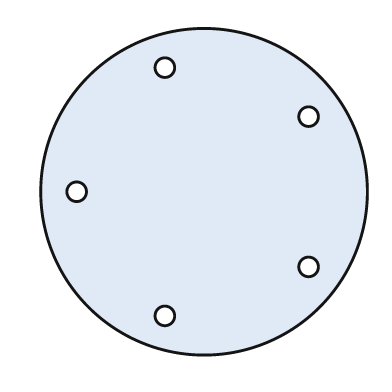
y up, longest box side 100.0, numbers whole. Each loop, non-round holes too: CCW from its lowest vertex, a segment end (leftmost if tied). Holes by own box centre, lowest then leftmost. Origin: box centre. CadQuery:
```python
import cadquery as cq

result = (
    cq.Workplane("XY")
    .moveTo(0.0, 0.0)
    .circle(50.0)
    .moveTo(-12.0, -38.0)
    .circle(3.0)
    .moveTo(32.0, -23.0)
    .circle(3.0)
    .moveTo(-39.0, 0.0)
    .circle(3.0)
    .moveTo(32.0, 23.0)
    .circle(3.0)
    .moveTo(-12.0, 38.0)
    .circle(3.0)
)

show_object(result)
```